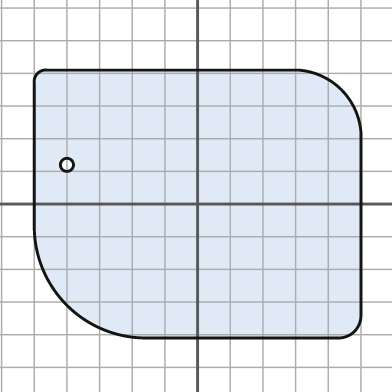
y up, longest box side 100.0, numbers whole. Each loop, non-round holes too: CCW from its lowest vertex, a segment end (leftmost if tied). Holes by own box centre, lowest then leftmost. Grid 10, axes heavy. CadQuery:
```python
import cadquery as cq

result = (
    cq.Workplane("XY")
    .moveTo(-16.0, -41.0)
    .lineTo(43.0, -41.0)
    .threePointArc((48.0, -39.0), (50.0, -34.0))
    .lineTo(50.0, 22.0)
    .threePointArc((44.0, 35.0), (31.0, 41.0))
    .lineTo(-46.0, 41.0)
    .threePointArc((-49.0, 40.0), (-50.0, 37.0))
    .lineTo(-50.0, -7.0)
    .threePointArc((-40.0, -31.0), (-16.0, -41.0))
    .close()
    .moveTo(-40.0, 12.0)
    .circle(2.0)
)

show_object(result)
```